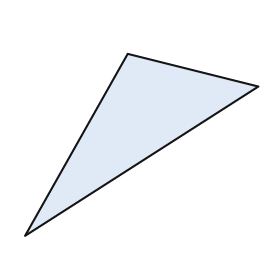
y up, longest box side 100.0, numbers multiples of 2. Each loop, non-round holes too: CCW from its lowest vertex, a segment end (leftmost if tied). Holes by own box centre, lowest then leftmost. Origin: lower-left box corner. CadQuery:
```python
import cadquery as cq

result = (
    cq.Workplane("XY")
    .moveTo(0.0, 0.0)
    .lineTo(100.0, 64.0)
    .lineTo(44.0, 78.0)
    .close()
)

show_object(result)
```